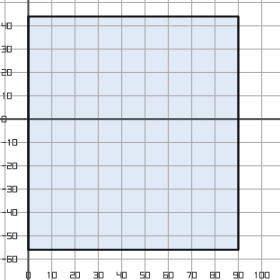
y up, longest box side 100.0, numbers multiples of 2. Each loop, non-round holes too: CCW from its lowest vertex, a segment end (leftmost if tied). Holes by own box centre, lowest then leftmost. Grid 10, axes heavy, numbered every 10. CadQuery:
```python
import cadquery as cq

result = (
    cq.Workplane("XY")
    .moveTo(0.0, -56.0)
    .lineTo(90.0, -56.0)
    .lineTo(90.0, 44.0)
    .lineTo(0.0, 44.0)
    .close()
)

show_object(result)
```